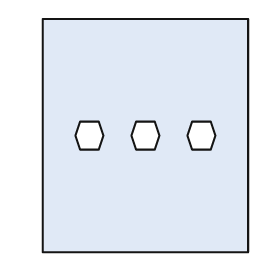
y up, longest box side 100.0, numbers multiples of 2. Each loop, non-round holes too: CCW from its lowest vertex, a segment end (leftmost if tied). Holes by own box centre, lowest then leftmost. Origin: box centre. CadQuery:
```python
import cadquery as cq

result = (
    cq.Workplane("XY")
    .moveTo(-44.0, -50.0)
    .lineTo(44.0, -50.0)
    .lineTo(44.0, 50.0)
    .lineTo(-44.0, 50.0)
    .close()
    .moveTo(-28.0, -6.0)
    .lineTo(-20.0, -6.0)
    .lineTo(-18.0, 0.0)
    .lineTo(-20.0, 6.0)
    .lineTo(-28.0, 6.0)
    .lineTo(-30.0, 0.0)
    .close()
    .moveTo(-4.0, -6.0)
    .lineTo(4.0, -6.0)
    .lineTo(6.0, 0.0)
    .lineTo(4.0, 6.0)
    .lineTo(-4.0, 6.0)
    .lineTo(-6.0, 0.0)
    .close()
    .moveTo(20.0, -6.0)
    .lineTo(28.0, -6.0)
    .lineTo(30.0, 0.0)
    .lineTo(28.0, 6.0)
    .lineTo(20.0, 6.0)
    .lineTo(18.0, 0.0)
    .close()
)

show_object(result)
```